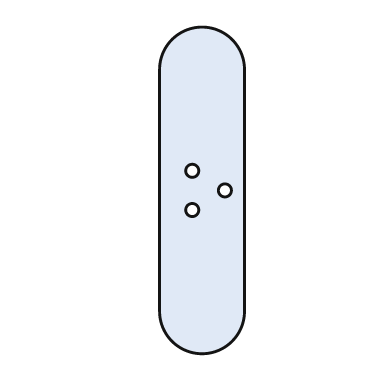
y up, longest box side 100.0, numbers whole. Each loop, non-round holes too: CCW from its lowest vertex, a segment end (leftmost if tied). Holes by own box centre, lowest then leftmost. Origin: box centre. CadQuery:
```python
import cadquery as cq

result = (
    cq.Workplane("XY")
    .moveTo(-13.0, -37.0)
    .threePointArc((0.0, -50.0), (13.0, -37.0))
    .lineTo(13.0, 37.0)
    .threePointArc((0.0, 50.0), (-13.0, 37.0))
    .close()
    .moveTo(-3.0, -6.0)
    .circle(2.0)
    .moveTo(7.0, 0.0)
    .circle(2.0)
    .moveTo(-3.0, 6.0)
    .circle(2.0)
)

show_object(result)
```